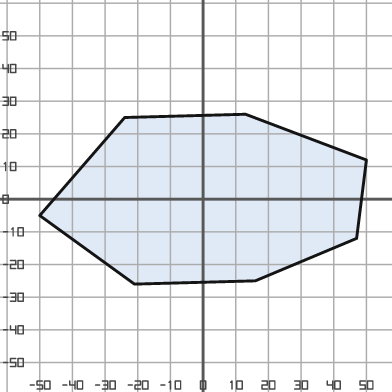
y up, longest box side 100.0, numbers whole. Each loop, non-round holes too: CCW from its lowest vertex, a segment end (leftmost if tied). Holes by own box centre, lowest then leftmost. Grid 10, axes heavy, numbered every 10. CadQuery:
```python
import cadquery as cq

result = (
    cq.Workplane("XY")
    .moveTo(-21.0, -26.0)
    .lineTo(16.0, -25.0)
    .lineTo(47.0, -12.0)
    .lineTo(50.0, 12.0)
    .lineTo(13.0, 26.0)
    .lineTo(-24.0, 25.0)
    .lineTo(-50.0, -5.0)
    .close()
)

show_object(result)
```